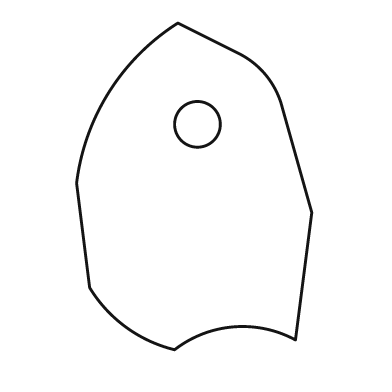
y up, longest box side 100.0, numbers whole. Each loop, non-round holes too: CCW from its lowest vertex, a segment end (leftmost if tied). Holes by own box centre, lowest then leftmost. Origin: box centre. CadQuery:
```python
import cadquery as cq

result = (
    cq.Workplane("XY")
    .moveTo(-6.0, -50.0)
    .threePointArc((12.0, -43.0), (31.0, -47.0))
    .lineTo(36.0, -8.0)
    .lineTo(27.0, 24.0)
    .threePointArc((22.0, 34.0), (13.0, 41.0))
    .lineTo(-5.0, 50.0)
    .threePointArc((-26.0, 29.0), (-36.0, 1.0))
    .lineTo(-32.0, -31.0)
    .threePointArc((-21.0, -43.0), (-6.0, -50.0))
    .close()
    .moveTo(1.0, 19.0)
    .circle(7.0)
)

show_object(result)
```